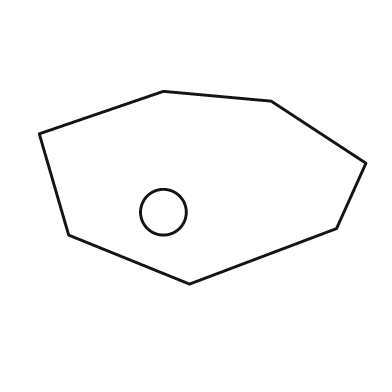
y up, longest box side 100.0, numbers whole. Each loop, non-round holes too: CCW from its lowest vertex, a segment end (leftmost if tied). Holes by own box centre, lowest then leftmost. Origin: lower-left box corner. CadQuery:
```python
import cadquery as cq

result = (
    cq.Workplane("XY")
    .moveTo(46.0, 0.0)
    .lineTo(91.0, 17.0)
    .lineTo(100.0, 37.0)
    .lineTo(71.0, 56.0)
    .lineTo(38.0, 59.0)
    .lineTo(0.0, 46.0)
    .lineTo(9.0, 15.0)
    .close()
    .moveTo(38.0, 22.0)
    .circle(7.0)
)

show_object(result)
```